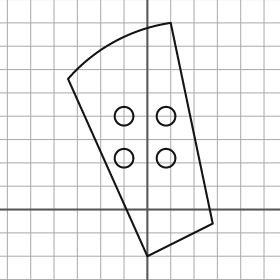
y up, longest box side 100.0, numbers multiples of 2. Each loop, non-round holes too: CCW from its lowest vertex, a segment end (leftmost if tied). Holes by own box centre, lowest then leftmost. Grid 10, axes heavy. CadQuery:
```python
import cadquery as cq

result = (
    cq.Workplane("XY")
    .moveTo(0.0, -20.0)
    .lineTo(28.0, -6.0)
    .lineTo(10.0, 80.0)
    .threePointArc((-14.0, 72.0), (-34.0, 56.0))
    .close()
    .moveTo(-10.0, 22.0)
    .circle(4.0)
    .moveTo(8.0, 22.0)
    .circle(4.0)
    .moveTo(-10.0, 40.0)
    .circle(4.0)
    .moveTo(8.0, 40.0)
    .circle(4.0)
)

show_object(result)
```